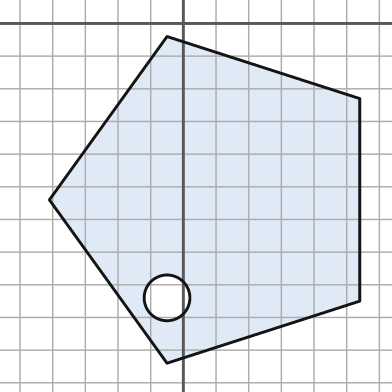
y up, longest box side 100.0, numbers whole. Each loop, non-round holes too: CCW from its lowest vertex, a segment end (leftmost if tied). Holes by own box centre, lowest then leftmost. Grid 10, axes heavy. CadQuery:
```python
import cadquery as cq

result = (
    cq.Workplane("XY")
    .moveTo(-5.0, -104.0)
    .lineTo(54.0, -85.0)
    .lineTo(54.0, -23.0)
    .lineTo(-5.0, -4.0)
    .lineTo(-41.0, -54.0)
    .close()
    .moveTo(-5.0, -84.0)
    .circle(7.0)
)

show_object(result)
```